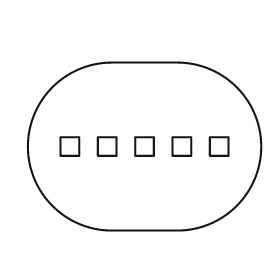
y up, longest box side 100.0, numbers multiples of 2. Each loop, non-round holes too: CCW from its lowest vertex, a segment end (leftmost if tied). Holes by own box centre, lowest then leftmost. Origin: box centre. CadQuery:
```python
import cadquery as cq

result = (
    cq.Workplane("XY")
    .moveTo(-14.0, -36.0)
    .lineTo(14.0, -36.0)
    .threePointArc((50.0, 0.0), (14.0, 36.0))
    .lineTo(-14.0, 36.0)
    .threePointArc((-50.0, 0.0), (-14.0, -36.0))
    .close()
    .moveTo(-36.0, -4.0)
    .lineTo(-28.0, -4.0)
    .lineTo(-28.0, 4.0)
    .lineTo(-36.0, 4.0)
    .close()
    .moveTo(-20.0, -4.0)
    .lineTo(-12.0, -4.0)
    .lineTo(-12.0, 4.0)
    .lineTo(-20.0, 4.0)
    .close()
    .moveTo(-4.0, -4.0)
    .lineTo(4.0, -4.0)
    .lineTo(4.0, 4.0)
    .lineTo(-4.0, 4.0)
    .close()
    .moveTo(12.0, -4.0)
    .lineTo(20.0, -4.0)
    .lineTo(20.0, 4.0)
    .lineTo(12.0, 4.0)
    .close()
    .moveTo(28.0, -4.0)
    .lineTo(36.0, -4.0)
    .lineTo(36.0, 4.0)
    .lineTo(28.0, 4.0)
    .close()
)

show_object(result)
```